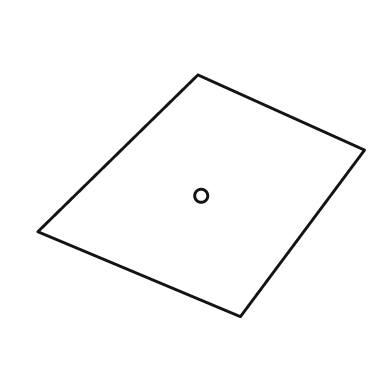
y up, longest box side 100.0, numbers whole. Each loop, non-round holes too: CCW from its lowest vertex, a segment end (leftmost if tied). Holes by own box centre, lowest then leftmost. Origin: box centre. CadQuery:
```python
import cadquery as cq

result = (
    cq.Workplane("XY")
    .moveTo(12.0, -37.0)
    .lineTo(50.0, 14.0)
    .lineTo(-1.0, 37.0)
    .lineTo(-50.0, -11.0)
    .close()
    .moveTo(0.0, 0.0)
    .circle(2.0)
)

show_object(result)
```